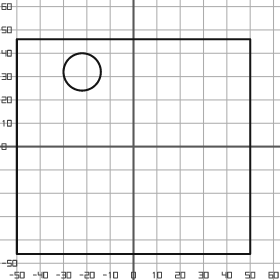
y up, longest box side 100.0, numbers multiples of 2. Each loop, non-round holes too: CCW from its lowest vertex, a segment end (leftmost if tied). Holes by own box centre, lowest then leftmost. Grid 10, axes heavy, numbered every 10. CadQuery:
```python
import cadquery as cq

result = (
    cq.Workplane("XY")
    .moveTo(-50.0, -46.0)
    .lineTo(50.0, -46.0)
    .lineTo(50.0, 46.0)
    .lineTo(-50.0, 46.0)
    .close()
    .moveTo(-22.0, 32.0)
    .circle(8.0)
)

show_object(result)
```